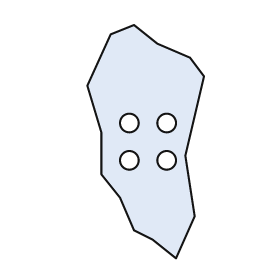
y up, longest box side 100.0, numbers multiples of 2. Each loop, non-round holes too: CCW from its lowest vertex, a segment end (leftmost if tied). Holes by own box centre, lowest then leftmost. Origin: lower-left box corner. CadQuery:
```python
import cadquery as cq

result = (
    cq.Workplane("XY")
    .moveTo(38.0, 0.0)
    .lineTo(46.0, 18.0)
    .lineTo(42.0, 44.0)
    .lineTo(50.0, 78.0)
    .lineTo(44.0, 86.0)
    .lineTo(30.0, 92.0)
    .lineTo(20.0, 100.0)
    .lineTo(10.0, 96.0)
    .lineTo(0.0, 74.0)
    .lineTo(6.0, 54.0)
    .lineTo(6.0, 36.0)
    .lineTo(14.0, 26.0)
    .lineTo(20.0, 12.0)
    .lineTo(28.0, 8.0)
    .close()
    .moveTo(18.0, 42.0)
    .circle(4.0)
    .moveTo(34.0, 42.0)
    .circle(4.0)
    .moveTo(18.0, 58.0)
    .circle(4.0)
    .moveTo(34.0, 58.0)
    .circle(4.0)
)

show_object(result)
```